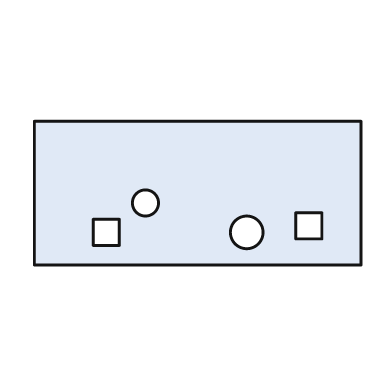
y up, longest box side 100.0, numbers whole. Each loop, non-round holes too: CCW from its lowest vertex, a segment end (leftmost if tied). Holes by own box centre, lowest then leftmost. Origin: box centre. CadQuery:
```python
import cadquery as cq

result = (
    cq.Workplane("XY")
    .moveTo(-50.0, -22.0)
    .lineTo(50.0, -22.0)
    .lineTo(50.0, 22.0)
    .lineTo(-50.0, 22.0)
    .close()
    .moveTo(-32.0, -16.0)
    .lineTo(-24.0, -16.0)
    .lineTo(-24.0, -8.0)
    .lineTo(-32.0, -8.0)
    .close()
    .moveTo(15.0, -12.0)
    .circle(5.0)
    .moveTo(30.0, -14.0)
    .lineTo(38.0, -14.0)
    .lineTo(38.0, -6.0)
    .lineTo(30.0, -6.0)
    .close()
    .moveTo(-16.0, -3.0)
    .circle(4.0)
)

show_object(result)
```